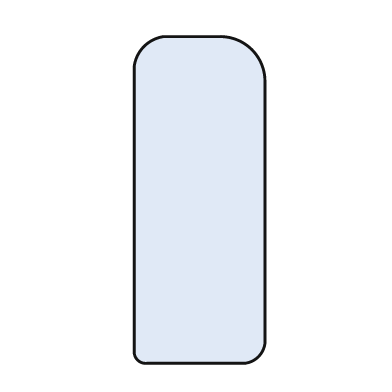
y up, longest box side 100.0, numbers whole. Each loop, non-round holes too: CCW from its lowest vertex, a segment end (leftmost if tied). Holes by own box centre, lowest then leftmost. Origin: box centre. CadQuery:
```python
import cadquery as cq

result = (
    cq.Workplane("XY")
    .moveTo(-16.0, -50.0)
    .lineTo(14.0, -50.0)
    .threePointArc((18.0, -48.0), (20.0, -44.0))
    .lineTo(20.0, 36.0)
    .threePointArc((16.0, 46.0), (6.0, 50.0))
    .lineTo(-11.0, 50.0)
    .threePointArc((-17.0, 47.0), (-20.0, 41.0))
    .lineTo(-20.0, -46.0)
    .threePointArc((-19.0, -49.0), (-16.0, -50.0))
    .close()
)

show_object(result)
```